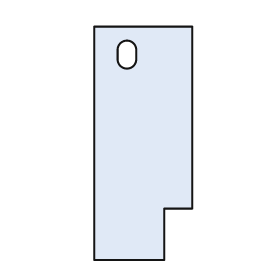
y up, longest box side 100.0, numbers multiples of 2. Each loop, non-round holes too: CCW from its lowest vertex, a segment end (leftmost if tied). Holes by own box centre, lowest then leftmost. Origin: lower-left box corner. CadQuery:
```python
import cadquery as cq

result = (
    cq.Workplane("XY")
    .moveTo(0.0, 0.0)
    .lineTo(30.0, 0.0)
    .lineTo(30.0, 22.0)
    .lineTo(42.0, 22.0)
    .lineTo(42.0, 100.0)
    .lineTo(0.0, 100.0)
    .close()
    .moveTo(10.0, 86.0)
    .threePointArc((14.0, 82.0), (18.0, 86.0))
    .lineTo(18.0, 90.0)
    .threePointArc((14.0, 94.0), (10.0, 90.0))
    .close()
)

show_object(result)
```